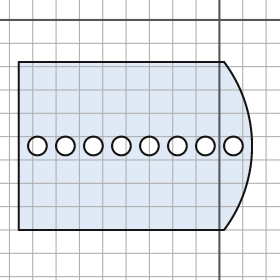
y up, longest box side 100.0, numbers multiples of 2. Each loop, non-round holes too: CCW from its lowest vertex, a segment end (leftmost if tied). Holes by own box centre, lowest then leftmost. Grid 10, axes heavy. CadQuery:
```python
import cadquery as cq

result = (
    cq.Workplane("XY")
    .moveTo(-86.0, -90.0)
    .lineTo(2.0, -90.0)
    .threePointArc((14.0, -54.0), (2.0, -18.0))
    .lineTo(-86.0, -18.0)
    .close()
    .moveTo(-78.0, -54.0)
    .circle(4.0)
    .moveTo(-66.0, -54.0)
    .circle(4.0)
    .moveTo(-54.0, -54.0)
    .circle(4.0)
    .moveTo(-42.0, -54.0)
    .circle(4.0)
    .moveTo(-30.0, -54.0)
    .circle(4.0)
    .moveTo(-18.0, -54.0)
    .circle(4.0)
    .moveTo(-6.0, -54.0)
    .circle(4.0)
    .moveTo(6.0, -54.0)
    .circle(4.0)
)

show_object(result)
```